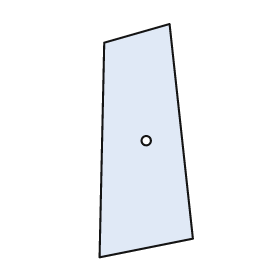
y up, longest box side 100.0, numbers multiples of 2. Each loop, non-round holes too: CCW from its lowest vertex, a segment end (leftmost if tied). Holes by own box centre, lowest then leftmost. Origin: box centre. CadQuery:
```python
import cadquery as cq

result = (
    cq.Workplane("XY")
    .moveTo(-20.0, -50.0)
    .lineTo(20.0, -42.0)
    .lineTo(10.0, 50.0)
    .lineTo(-18.0, 42.0)
    .close()
    .moveTo(0.0, 0.0)
    .circle(2.0)
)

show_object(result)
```